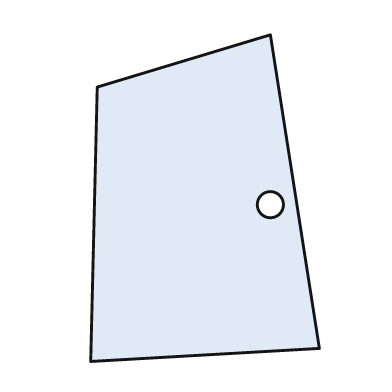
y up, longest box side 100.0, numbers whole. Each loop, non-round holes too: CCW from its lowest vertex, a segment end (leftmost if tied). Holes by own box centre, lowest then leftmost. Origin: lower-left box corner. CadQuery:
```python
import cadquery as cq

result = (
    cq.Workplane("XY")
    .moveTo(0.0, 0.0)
    .lineTo(70.0, 4.0)
    .lineTo(55.0, 100.0)
    .lineTo(2.0, 84.0)
    .close()
    .moveTo(55.0, 48.0)
    .circle(4.0)
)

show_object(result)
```